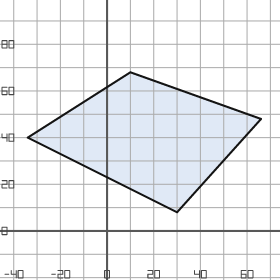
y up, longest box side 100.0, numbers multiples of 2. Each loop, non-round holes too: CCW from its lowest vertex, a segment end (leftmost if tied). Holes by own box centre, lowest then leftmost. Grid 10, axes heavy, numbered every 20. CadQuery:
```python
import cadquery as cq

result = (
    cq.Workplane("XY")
    .moveTo(30.0, 8.0)
    .lineTo(66.0, 48.0)
    .lineTo(10.0, 68.0)
    .lineTo(-34.0, 40.0)
    .close()
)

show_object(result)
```